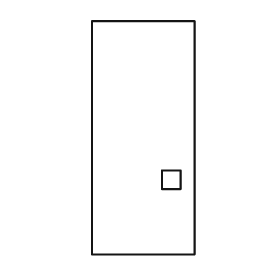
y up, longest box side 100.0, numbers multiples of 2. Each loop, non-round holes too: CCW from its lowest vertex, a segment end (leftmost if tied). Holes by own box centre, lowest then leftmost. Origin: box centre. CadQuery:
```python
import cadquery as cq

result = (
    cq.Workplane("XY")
    .moveTo(-22.0, -50.0)
    .lineTo(22.0, -50.0)
    .lineTo(22.0, 50.0)
    .lineTo(-22.0, 50.0)
    .close()
    .moveTo(8.0, -22.0)
    .lineTo(16.0, -22.0)
    .lineTo(16.0, -14.0)
    .lineTo(8.0, -14.0)
    .close()
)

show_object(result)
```